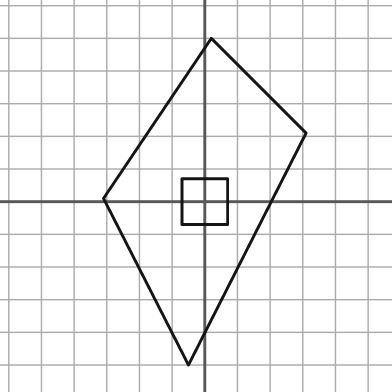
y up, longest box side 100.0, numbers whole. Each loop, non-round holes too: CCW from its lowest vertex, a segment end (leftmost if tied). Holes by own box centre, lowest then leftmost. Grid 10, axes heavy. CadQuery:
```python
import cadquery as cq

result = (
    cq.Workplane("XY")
    .moveTo(-5.0, -50.0)
    .lineTo(31.0, 21.0)
    .lineTo(2.0, 50.0)
    .lineTo(-31.0, 1.0)
    .close()
    .moveTo(-7.0, -7.0)
    .lineTo(7.0, -7.0)
    .lineTo(7.0, 7.0)
    .lineTo(-7.0, 7.0)
    .close()
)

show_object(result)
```